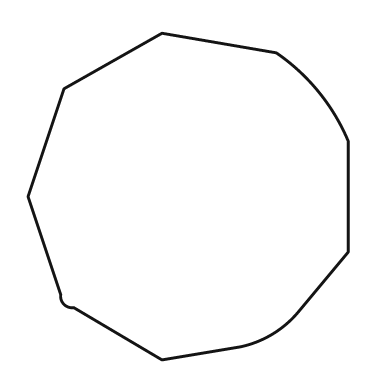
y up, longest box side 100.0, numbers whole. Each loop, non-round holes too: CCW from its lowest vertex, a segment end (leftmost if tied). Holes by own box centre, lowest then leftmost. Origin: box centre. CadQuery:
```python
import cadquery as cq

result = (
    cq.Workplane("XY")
    .moveTo(-8.0, -50.0)
    .lineTo(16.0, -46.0)
    .threePointArc((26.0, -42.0), (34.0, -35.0))
    .lineTo(49.0, -17.0)
    .lineTo(49.0, 17.0)
    .threePointArc((40.0, 32.0), (27.0, 44.0))
    .lineTo(-8.0, 50.0)
    .lineTo(-38.0, 33.0)
    .lineTo(-49.0, 0.0)
    .lineTo(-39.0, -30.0)
    .threePointArc((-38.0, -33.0), (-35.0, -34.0))
    .close()
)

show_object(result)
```